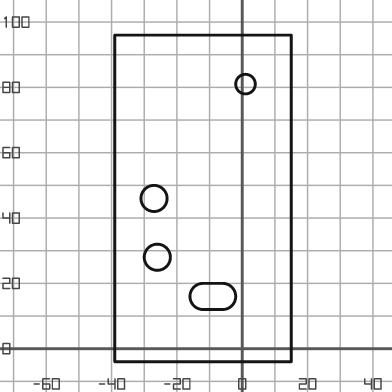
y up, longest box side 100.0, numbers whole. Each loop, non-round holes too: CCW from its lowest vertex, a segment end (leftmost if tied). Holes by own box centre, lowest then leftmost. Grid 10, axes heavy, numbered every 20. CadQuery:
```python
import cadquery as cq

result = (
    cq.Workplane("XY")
    .moveTo(-39.0, -4.0)
    .lineTo(15.0, -4.0)
    .lineTo(15.0, 96.0)
    .lineTo(-39.0, 96.0)
    .close()
    .moveTo(-12.0, 12.0)
    .lineTo(-6.0, 12.0)
    .threePointArc((-2.0, 16.0), (-6.0, 20.0))
    .lineTo(-12.0, 20.0)
    .threePointArc((-16.0, 16.0), (-12.0, 12.0))
    .close()
    .moveTo(-26.0, 28.0)
    .circle(4.0)
    .moveTo(-27.0, 46.0)
    .circle(4.0)
    .moveTo(1.0, 81.0)
    .circle(3.0)
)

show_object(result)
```